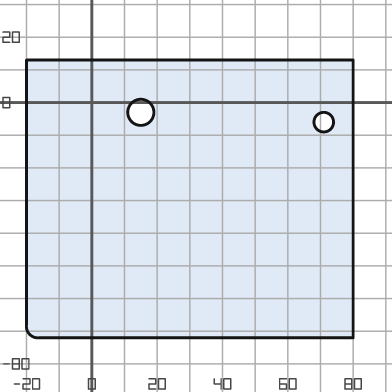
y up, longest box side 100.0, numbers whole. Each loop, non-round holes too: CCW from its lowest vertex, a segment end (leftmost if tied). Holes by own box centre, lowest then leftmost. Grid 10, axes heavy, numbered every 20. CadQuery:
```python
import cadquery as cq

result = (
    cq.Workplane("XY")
    .moveTo(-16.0, -72.0)
    .lineTo(80.0, -72.0)
    .lineTo(80.0, 13.0)
    .lineTo(-20.0, 13.0)
    .lineTo(-20.0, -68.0)
    .threePointArc((-19.0, -71.0), (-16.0, -72.0))
    .close()
    .moveTo(71.0, -6.0)
    .circle(3.0)
    .moveTo(15.0, -3.0)
    .circle(4.0)
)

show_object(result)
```